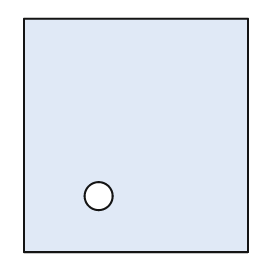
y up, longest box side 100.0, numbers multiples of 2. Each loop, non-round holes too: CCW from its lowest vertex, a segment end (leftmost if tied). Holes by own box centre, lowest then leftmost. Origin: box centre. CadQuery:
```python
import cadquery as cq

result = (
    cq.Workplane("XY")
    .moveTo(-48.0, -50.0)
    .lineTo(48.0, -50.0)
    .lineTo(48.0, 50.0)
    .lineTo(-48.0, 50.0)
    .close()
    .moveTo(-16.0, -26.0)
    .circle(6.0)
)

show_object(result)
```